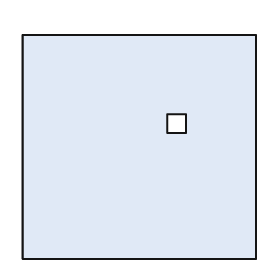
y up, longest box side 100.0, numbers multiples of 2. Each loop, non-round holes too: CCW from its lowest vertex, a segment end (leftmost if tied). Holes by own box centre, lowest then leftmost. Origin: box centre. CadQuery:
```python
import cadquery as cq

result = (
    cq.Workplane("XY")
    .moveTo(-50.0, -48.0)
    .lineTo(50.0, -48.0)
    .lineTo(50.0, 48.0)
    .lineTo(-50.0, 48.0)
    .close()
    .moveTo(12.0, 6.0)
    .lineTo(20.0, 6.0)
    .lineTo(20.0, 14.0)
    .lineTo(12.0, 14.0)
    .close()
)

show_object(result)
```